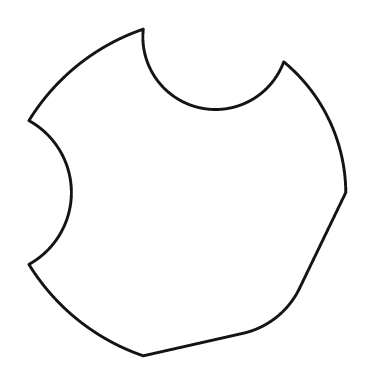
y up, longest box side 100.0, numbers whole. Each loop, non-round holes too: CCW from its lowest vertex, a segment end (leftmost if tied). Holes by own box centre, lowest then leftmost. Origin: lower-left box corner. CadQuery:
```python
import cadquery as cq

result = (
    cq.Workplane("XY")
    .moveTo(35.0, 0.0)
    .lineTo(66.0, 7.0)
    .threePointArc((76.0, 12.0), (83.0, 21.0))
    .lineTo(97.0, 50.0)
    .threePointArc((92.0, 72.0), (78.0, 90.0))
    .threePointArc((52.0, 76.0), (35.0, 100.0))
    .threePointArc((15.0, 89.0), (0.0, 72.0))
    .threePointArc((13.0, 50.0), (0.0, 28.0))
    .threePointArc((15.0, 11.0), (35.0, 0.0))
    .close()
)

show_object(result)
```